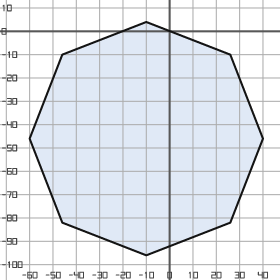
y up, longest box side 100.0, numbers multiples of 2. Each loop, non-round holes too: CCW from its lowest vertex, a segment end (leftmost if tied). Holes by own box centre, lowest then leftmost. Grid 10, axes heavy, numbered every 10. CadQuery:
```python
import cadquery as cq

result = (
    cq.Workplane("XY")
    .moveTo(-10.0, -96.0)
    .lineTo(26.0, -82.0)
    .lineTo(40.0, -46.0)
    .lineTo(26.0, -10.0)
    .lineTo(-10.0, 4.0)
    .lineTo(-46.0, -10.0)
    .lineTo(-60.0, -46.0)
    .lineTo(-46.0, -82.0)
    .close()
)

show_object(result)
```